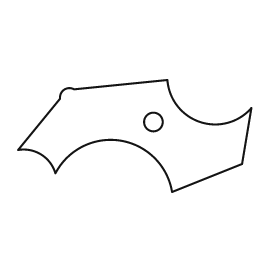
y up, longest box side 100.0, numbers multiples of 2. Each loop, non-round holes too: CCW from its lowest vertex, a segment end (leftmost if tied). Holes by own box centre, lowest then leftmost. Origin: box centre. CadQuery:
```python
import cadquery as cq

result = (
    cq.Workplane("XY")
    .moveTo(16.0, -24.0)
    .lineTo(46.0, -12.0)
    .lineTo(50.0, 12.0)
    .threePointArc((28.0, 6.0), (14.0, 24.0))
    .lineTo(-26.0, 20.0)
    .threePointArc((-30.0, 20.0), (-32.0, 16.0))
    .lineTo(-50.0, -6.0)
    .threePointArc((-40.0, -8.0), (-34.0, -16.0))
    .threePointArc((-6.0, -2.0), (16.0, -24.0))
    .close()
    .moveTo(8.0, 6.0)
    .circle(4.0)
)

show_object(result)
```